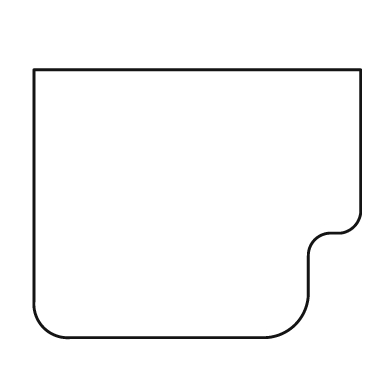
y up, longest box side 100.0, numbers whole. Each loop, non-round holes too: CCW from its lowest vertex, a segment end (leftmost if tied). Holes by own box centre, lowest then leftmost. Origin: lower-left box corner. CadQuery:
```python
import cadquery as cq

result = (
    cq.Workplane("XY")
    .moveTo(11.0, 0.0)
    .lineTo(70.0, 0.0)
    .threePointArc((80.0, 4.0), (84.0, 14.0))
    .lineTo(84.0, 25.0)
    .threePointArc((86.0, 30.0), (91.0, 32.0))
    .lineTo(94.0, 32.0)
    .threePointArc((98.0, 34.0), (100.0, 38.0))
    .lineTo(100.0, 82.0)
    .lineTo(0.0, 82.0)
    .lineTo(0.0, 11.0)
    .threePointArc((3.0, 3.0), (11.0, 0.0))
    .close()
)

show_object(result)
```